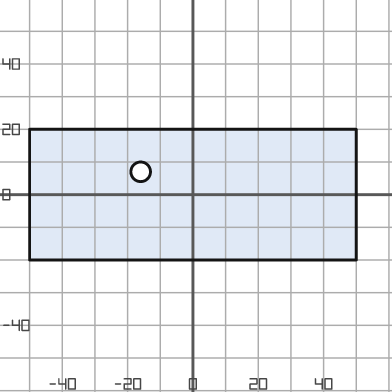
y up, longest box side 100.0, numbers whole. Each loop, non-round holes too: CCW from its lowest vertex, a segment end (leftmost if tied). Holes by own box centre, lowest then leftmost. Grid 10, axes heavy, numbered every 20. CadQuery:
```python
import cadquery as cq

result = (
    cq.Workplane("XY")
    .moveTo(-50.0, -20.0)
    .lineTo(50.0, -20.0)
    .lineTo(50.0, 20.0)
    .lineTo(-50.0, 20.0)
    .close()
    .moveTo(-16.0, 7.0)
    .circle(3.0)
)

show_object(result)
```